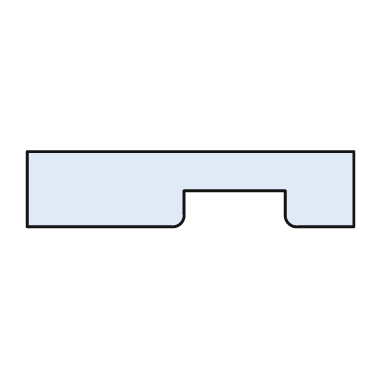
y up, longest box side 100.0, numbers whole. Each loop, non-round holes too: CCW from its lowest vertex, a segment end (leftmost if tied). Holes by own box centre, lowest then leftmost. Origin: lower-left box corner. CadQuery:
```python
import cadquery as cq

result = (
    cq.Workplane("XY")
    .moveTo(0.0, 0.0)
    .lineTo(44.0, 0.0)
    .threePointArc((47.0, 1.0), (48.0, 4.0))
    .lineTo(48.0, 11.0)
    .lineTo(79.0, 11.0)
    .lineTo(79.0, 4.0)
    .threePointArc((80.0, 1.0), (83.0, 0.0))
    .lineTo(100.0, 0.0)
    .lineTo(100.0, 23.0)
    .lineTo(0.0, 23.0)
    .close()
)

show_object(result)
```